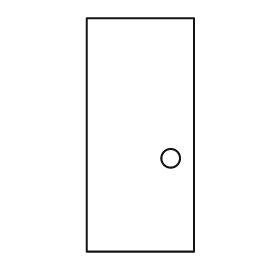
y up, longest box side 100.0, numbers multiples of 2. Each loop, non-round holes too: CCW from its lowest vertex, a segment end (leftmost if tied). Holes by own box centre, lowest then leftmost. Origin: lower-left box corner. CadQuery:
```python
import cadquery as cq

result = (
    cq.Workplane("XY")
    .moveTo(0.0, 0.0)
    .lineTo(46.0, 0.0)
    .lineTo(46.0, 100.0)
    .lineTo(0.0, 100.0)
    .close()
    .moveTo(36.0, 40.0)
    .circle(4.0)
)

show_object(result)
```